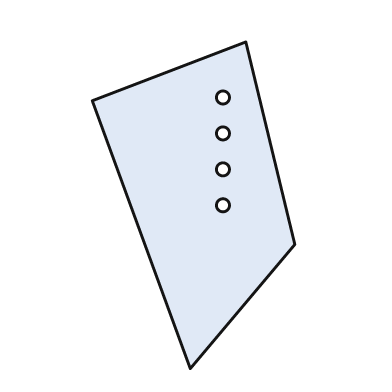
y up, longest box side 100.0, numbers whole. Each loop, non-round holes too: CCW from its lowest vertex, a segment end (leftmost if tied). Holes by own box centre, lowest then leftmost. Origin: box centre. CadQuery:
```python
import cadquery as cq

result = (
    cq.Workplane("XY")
    .moveTo(-1.0, -50.0)
    .lineTo(31.0, -12.0)
    .lineTo(16.0, 50.0)
    .lineTo(-31.0, 32.0)
    .close()
    .moveTo(9.0, 0.0)
    .circle(2.0)
    .moveTo(9.0, 11.0)
    .circle(2.0)
    .moveTo(9.0, 22.0)
    .circle(2.0)
    .moveTo(9.0, 33.0)
    .circle(2.0)
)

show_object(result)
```